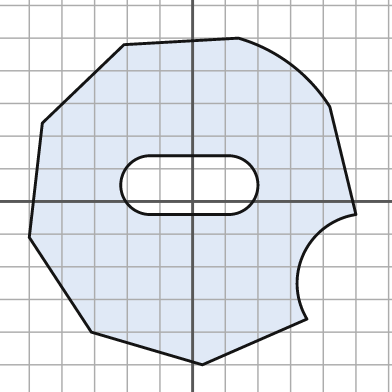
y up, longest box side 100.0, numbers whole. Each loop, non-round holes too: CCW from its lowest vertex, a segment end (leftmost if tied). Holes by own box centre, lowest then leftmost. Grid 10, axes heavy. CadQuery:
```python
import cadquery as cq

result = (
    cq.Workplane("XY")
    .moveTo(3.0, -50.0)
    .lineTo(35.0, -36.0)
    .threePointArc((34.0, -16.0), (50.0, -4.0))
    .lineTo(42.0, 29.0)
    .threePointArc((30.0, 42.0), (14.0, 50.0))
    .lineTo(-21.0, 48.0)
    .lineTo(-46.0, 24.0)
    .lineTo(-50.0, -11.0)
    .lineTo(-31.0, -40.0)
    .close()
    .moveTo(-13.0, -4.0)
    .lineTo(11.0, -4.0)
    .threePointArc((20.0, 5.0), (11.0, 14.0))
    .lineTo(-13.0, 14.0)
    .threePointArc((-22.0, 5.0), (-13.0, -4.0))
    .close()
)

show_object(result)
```